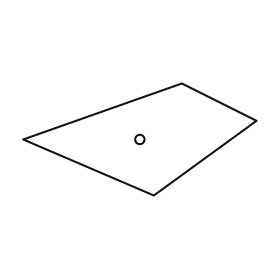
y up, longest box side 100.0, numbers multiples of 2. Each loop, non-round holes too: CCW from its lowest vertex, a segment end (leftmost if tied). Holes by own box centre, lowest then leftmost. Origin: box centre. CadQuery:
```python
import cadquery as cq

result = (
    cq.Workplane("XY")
    .moveTo(6.0, -24.0)
    .lineTo(50.0, 8.0)
    .lineTo(18.0, 24.0)
    .lineTo(-50.0, 0.0)
    .close()
    .moveTo(0.0, 0.0)
    .circle(2.0)
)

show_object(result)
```